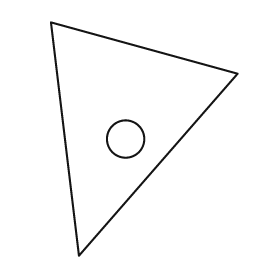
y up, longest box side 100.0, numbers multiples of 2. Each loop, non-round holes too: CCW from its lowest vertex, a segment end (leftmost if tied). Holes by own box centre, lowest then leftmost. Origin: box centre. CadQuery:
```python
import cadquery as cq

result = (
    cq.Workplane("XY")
    .moveTo(-28.0, -50.0)
    .lineTo(40.0, 28.0)
    .lineTo(-40.0, 50.0)
    .close()
    .moveTo(-8.0, 0.0)
    .circle(8.0)
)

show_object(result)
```